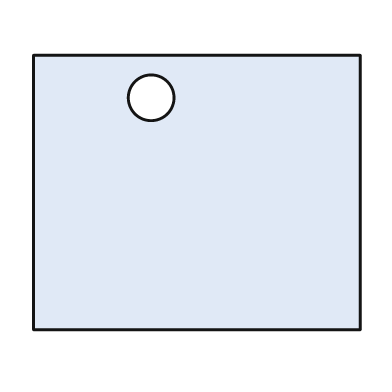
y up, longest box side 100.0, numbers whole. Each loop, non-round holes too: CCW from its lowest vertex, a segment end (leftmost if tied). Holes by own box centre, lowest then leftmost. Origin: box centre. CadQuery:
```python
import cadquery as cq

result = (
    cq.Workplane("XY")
    .moveTo(-50.0, -42.0)
    .lineTo(50.0, -42.0)
    .lineTo(50.0, 42.0)
    .lineTo(-50.0, 42.0)
    .close()
    .moveTo(-14.0, 29.0)
    .circle(7.0)
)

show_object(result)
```